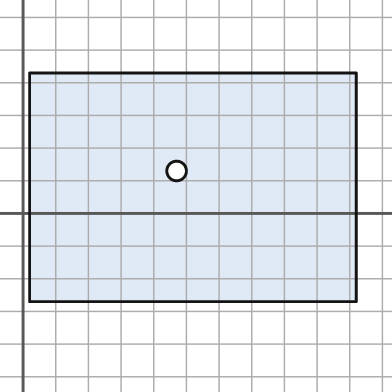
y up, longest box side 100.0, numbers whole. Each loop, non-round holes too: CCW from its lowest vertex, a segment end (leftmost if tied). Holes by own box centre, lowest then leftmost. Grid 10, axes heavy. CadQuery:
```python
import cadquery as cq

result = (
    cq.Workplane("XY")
    .moveTo(2.0, -27.0)
    .lineTo(102.0, -27.0)
    .lineTo(102.0, 43.0)
    .lineTo(2.0, 43.0)
    .close()
    .moveTo(47.0, 13.0)
    .circle(3.0)
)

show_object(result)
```